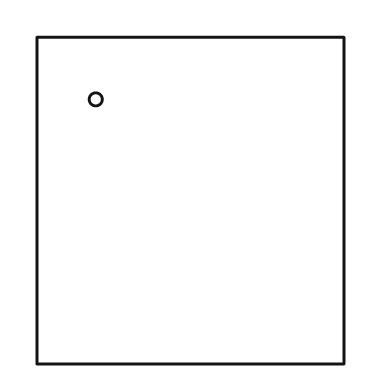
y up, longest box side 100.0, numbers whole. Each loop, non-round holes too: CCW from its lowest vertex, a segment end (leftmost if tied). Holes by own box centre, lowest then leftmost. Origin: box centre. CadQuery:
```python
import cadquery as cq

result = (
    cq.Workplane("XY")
    .moveTo(-47.0, -50.0)
    .lineTo(47.0, -50.0)
    .lineTo(47.0, 50.0)
    .lineTo(-47.0, 50.0)
    .close()
    .moveTo(-29.0, 31.0)
    .circle(2.0)
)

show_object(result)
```